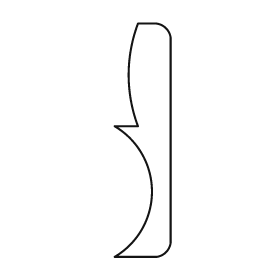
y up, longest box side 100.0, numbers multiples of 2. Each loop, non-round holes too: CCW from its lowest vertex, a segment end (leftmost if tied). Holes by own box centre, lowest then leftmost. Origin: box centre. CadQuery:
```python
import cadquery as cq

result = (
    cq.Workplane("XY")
    .moveTo(-12.0, -50.0)
    .lineTo(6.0, -50.0)
    .threePointArc((10.0, -48.0), (12.0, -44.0))
    .lineTo(12.0, 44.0)
    .threePointArc((10.0, 48.0), (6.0, 50.0))
    .lineTo(-2.0, 50.0)
    .threePointArc((-6.0, 28.0), (-2.0, 6.0))
    .lineTo(-12.0, 6.0)
    .threePointArc((4.0, -22.0), (-12.0, -50.0))
    .close()
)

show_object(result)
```